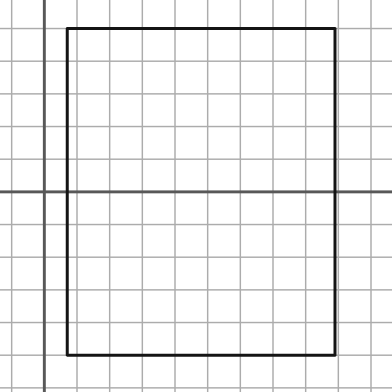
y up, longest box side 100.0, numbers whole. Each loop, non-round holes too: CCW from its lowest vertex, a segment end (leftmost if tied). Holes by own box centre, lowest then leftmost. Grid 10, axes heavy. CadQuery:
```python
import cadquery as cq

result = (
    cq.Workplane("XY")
    .moveTo(7.0, -50.0)
    .lineTo(89.0, -50.0)
    .lineTo(89.0, 50.0)
    .lineTo(7.0, 50.0)
    .close()
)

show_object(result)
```